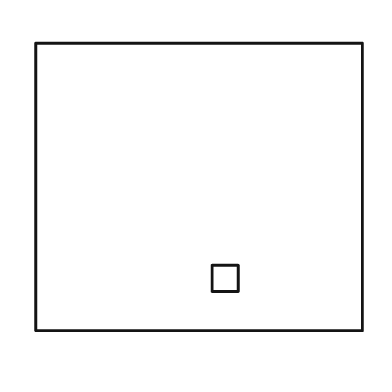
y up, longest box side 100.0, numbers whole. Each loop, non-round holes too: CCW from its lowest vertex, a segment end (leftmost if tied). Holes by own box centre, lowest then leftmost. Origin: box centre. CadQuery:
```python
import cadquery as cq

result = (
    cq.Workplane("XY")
    .moveTo(-50.0, -44.0)
    .lineTo(50.0, -44.0)
    .lineTo(50.0, 44.0)
    .lineTo(-50.0, 44.0)
    .close()
    .moveTo(4.0, -32.0)
    .lineTo(12.0, -32.0)
    .lineTo(12.0, -24.0)
    .lineTo(4.0, -24.0)
    .close()
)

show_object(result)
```